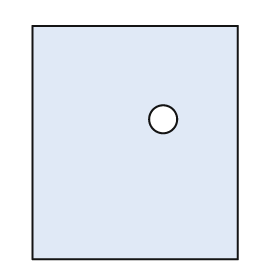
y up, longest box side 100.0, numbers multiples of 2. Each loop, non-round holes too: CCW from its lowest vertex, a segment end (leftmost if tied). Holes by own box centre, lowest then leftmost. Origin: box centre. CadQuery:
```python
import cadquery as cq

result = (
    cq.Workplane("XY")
    .moveTo(-44.0, -50.0)
    .lineTo(44.0, -50.0)
    .lineTo(44.0, 50.0)
    .lineTo(-44.0, 50.0)
    .close()
    .moveTo(12.0, 10.0)
    .circle(6.0)
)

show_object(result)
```